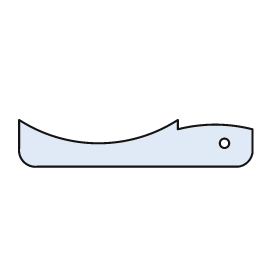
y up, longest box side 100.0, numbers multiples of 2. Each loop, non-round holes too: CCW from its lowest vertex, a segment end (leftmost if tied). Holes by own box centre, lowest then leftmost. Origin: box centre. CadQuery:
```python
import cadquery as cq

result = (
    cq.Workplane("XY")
    .moveTo(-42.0, -10.0)
    .lineTo(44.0, -10.0)
    .threePointArc((48.0, -8.0), (50.0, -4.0))
    .lineTo(50.0, 6.0)
    .threePointArc((34.0, 8.0), (18.0, 6.0))
    .lineTo(18.0, 10.0)
    .threePointArc((-16.0, 0.0), (-50.0, 10.0))
    .lineTo(-50.0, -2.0)
    .threePointArc((-48.0, -8.0), (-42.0, -10.0))
    .close()
    .moveTo(38.0, 0.0)
    .circle(2.0)
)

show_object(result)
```